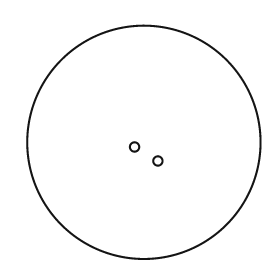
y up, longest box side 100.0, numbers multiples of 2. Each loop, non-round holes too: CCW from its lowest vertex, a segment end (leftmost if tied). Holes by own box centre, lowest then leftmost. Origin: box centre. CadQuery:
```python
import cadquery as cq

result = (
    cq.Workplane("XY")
    .moveTo(0.0, 0.0)
    .circle(50.0)
    .moveTo(6.0, -8.0)
    .circle(2.0)
    .moveTo(-4.0, -2.0)
    .circle(2.0)
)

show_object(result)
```